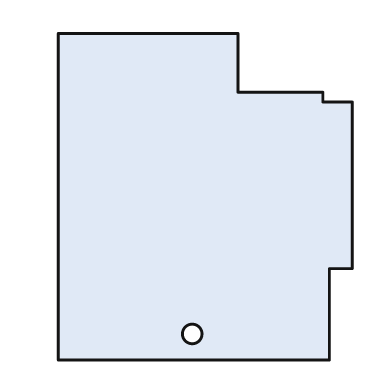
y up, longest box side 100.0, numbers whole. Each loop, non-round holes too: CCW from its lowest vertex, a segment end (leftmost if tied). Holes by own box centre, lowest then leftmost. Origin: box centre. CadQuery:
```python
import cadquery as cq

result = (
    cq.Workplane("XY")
    .moveTo(-45.0, -50.0)
    .lineTo(38.0, -50.0)
    .lineTo(38.0, -22.0)
    .lineTo(45.0, -22.0)
    .lineTo(45.0, 29.0)
    .lineTo(36.0, 29.0)
    .lineTo(36.0, 32.0)
    .lineTo(10.0, 32.0)
    .lineTo(10.0, 50.0)
    .lineTo(-45.0, 50.0)
    .close()
    .moveTo(-4.0, -42.0)
    .circle(3.0)
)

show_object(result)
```